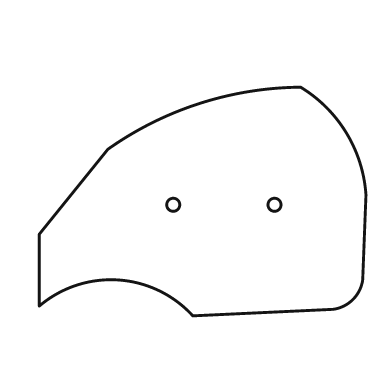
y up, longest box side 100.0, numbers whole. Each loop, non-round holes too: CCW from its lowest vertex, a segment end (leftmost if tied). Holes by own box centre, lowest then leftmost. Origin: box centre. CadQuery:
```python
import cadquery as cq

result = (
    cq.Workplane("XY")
    .moveTo(-3.0, -35.0)
    .lineTo(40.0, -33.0)
    .threePointArc((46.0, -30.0), (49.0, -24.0))
    .lineTo(50.0, 2.0)
    .threePointArc((44.0, 21.0), (30.0, 35.0))
    .threePointArc((-1.0, 30.0), (-29.0, 16.0))
    .lineTo(-50.0, -10.0)
    .lineTo(-50.0, -32.0)
    .threePointArc((-26.0, -24.0), (-3.0, -35.0))
    .close()
    .moveTo(-9.0, -1.0)
    .circle(2.0)
    .moveTo(22.0, -1.0)
    .circle(2.0)
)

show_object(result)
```